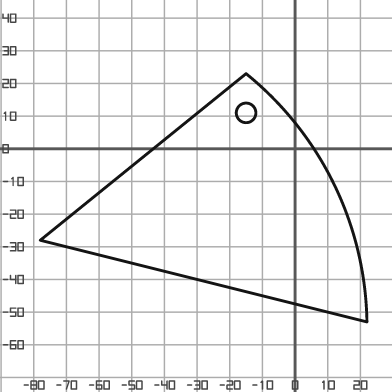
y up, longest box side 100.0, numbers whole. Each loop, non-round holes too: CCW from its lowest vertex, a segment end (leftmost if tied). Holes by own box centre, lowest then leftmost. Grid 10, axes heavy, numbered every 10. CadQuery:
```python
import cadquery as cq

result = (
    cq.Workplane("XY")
    .moveTo(22.0, -53.0)
    .threePointArc((12.0, -11.0), (-15.0, 23.0))
    .lineTo(-78.0, -28.0)
    .close()
    .moveTo(-15.0, 11.0)
    .circle(3.0)
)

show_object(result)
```